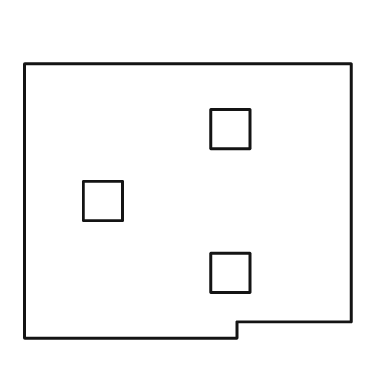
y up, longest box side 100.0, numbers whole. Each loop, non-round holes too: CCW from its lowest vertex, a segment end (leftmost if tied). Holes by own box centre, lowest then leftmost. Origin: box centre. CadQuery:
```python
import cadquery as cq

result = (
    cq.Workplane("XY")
    .moveTo(-50.0, -42.0)
    .lineTo(15.0, -42.0)
    .lineTo(15.0, -37.0)
    .lineTo(50.0, -37.0)
    .lineTo(50.0, 42.0)
    .lineTo(-50.0, 42.0)
    .close()
    .moveTo(7.0, -28.0)
    .lineTo(19.0, -28.0)
    .lineTo(19.0, -16.0)
    .lineTo(7.0, -16.0)
    .close()
    .moveTo(-32.0, -6.0)
    .lineTo(-20.0, -6.0)
    .lineTo(-20.0, 6.0)
    .lineTo(-32.0, 6.0)
    .close()
    .moveTo(7.0, 16.0)
    .lineTo(19.0, 16.0)
    .lineTo(19.0, 28.0)
    .lineTo(7.0, 28.0)
    .close()
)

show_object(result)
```